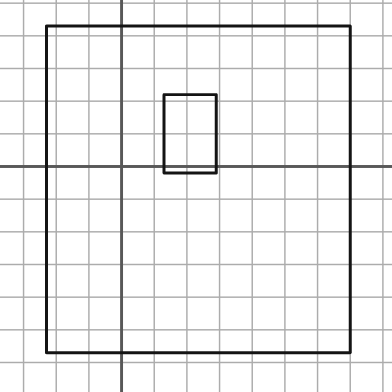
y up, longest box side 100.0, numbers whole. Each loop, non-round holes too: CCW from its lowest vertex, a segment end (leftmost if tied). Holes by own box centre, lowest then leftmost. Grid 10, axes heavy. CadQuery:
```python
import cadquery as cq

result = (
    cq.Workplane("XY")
    .moveTo(-23.0, -57.0)
    .lineTo(70.0, -57.0)
    .lineTo(70.0, 43.0)
    .lineTo(-23.0, 43.0)
    .close()
    .moveTo(13.0, -2.0)
    .lineTo(29.0, -2.0)
    .lineTo(29.0, 22.0)
    .lineTo(13.0, 22.0)
    .close()
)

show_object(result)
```